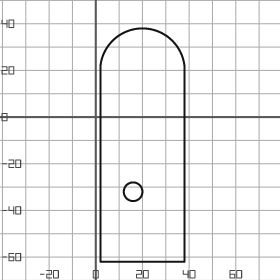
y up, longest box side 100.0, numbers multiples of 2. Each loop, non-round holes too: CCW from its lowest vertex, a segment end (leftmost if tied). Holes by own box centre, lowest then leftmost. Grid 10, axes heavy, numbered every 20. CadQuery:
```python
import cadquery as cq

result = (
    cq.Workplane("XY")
    .moveTo(2.0, -62.0)
    .lineTo(38.0, -62.0)
    .lineTo(38.0, 22.0)
    .threePointArc((20.0, 38.0), (2.0, 22.0))
    .close()
    .moveTo(16.0, -32.0)
    .circle(4.0)
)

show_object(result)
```